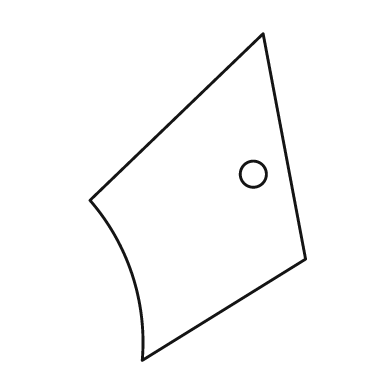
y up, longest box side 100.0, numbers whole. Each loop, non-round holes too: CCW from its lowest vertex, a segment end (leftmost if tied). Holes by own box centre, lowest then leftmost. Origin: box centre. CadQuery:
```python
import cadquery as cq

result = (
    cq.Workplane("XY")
    .moveTo(-17.0, -50.0)
    .lineTo(33.0, -19.0)
    .lineTo(20.0, 50.0)
    .lineTo(-33.0, -1.0)
    .threePointArc((-20.0, -24.0), (-17.0, -50.0))
    .close()
    .moveTo(17.0, 7.0)
    .circle(4.0)
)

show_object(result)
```